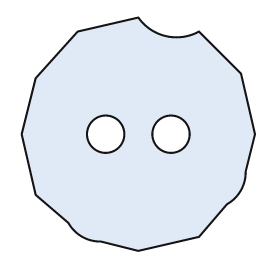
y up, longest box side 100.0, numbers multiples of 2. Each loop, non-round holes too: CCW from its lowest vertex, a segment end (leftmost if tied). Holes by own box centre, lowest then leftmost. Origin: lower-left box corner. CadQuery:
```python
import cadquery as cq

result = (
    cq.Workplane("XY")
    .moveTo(50.0, 0.0)
    .lineTo(76.0, 6.0)
    .lineTo(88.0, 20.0)
    .threePointArc((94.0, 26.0), (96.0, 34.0))
    .lineTo(100.0, 50.0)
    .lineTo(94.0, 76.0)
    .lineTo(76.0, 94.0)
    .threePointArc((62.0, 92.0), (50.0, 100.0))
    .lineTo(24.0, 94.0)
    .lineTo(6.0, 74.0)
    .lineTo(0.0, 50.0)
    .lineTo(6.0, 24.0)
    .lineTo(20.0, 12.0)
    .threePointArc((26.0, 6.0), (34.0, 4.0))
    .close()
    .moveTo(36.0, 50.0)
    .circle(8.0)
    .moveTo(64.0, 50.0)
    .circle(8.0)
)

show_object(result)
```